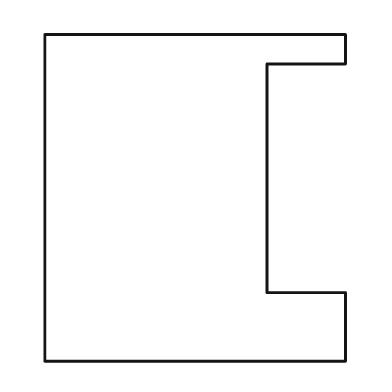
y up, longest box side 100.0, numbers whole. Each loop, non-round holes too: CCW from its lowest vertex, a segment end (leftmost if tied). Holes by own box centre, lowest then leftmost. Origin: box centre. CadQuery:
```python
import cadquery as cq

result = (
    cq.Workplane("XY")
    .moveTo(-46.0, -50.0)
    .lineTo(46.0, -50.0)
    .lineTo(46.0, -29.0)
    .lineTo(22.0, -29.0)
    .lineTo(22.0, 41.0)
    .lineTo(46.0, 41.0)
    .lineTo(46.0, 50.0)
    .lineTo(-46.0, 50.0)
    .close()
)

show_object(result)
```